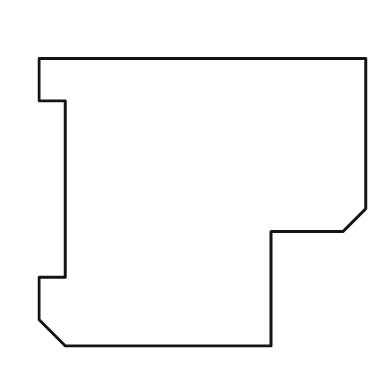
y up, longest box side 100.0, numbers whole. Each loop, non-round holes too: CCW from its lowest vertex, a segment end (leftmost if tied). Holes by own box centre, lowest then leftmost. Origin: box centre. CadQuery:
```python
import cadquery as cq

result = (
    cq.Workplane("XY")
    .moveTo(-42.0, -44.0)
    .lineTo(21.0, -44.0)
    .lineTo(21.0, -9.0)
    .lineTo(43.0, -9.0)
    .lineTo(50.0, -2.0)
    .lineTo(50.0, 44.0)
    .lineTo(-50.0, 44.0)
    .lineTo(-50.0, 31.0)
    .lineTo(-42.0, 31.0)
    .lineTo(-42.0, -23.0)
    .lineTo(-50.0, -23.0)
    .lineTo(-50.0, -36.0)
    .close()
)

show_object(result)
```